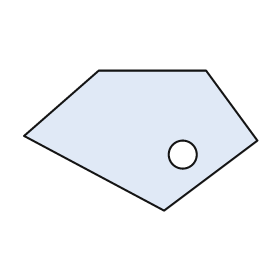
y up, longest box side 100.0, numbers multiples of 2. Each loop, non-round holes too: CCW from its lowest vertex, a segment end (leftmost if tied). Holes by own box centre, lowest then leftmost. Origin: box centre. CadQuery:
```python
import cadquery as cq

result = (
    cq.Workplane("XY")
    .moveTo(10.0, -30.0)
    .lineTo(50.0, 0.0)
    .lineTo(28.0, 30.0)
    .lineTo(-18.0, 30.0)
    .lineTo(-50.0, 2.0)
    .close()
    .moveTo(18.0, -6.0)
    .circle(6.0)
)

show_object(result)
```